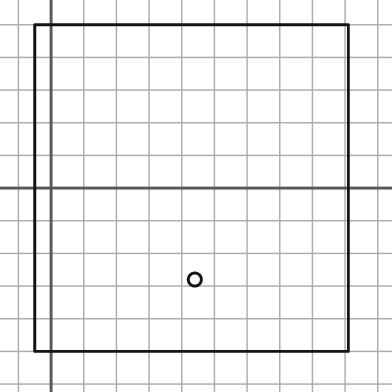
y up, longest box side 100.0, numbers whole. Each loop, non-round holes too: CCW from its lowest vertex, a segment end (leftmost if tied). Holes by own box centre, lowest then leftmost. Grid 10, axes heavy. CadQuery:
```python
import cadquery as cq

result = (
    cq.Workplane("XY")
    .moveTo(-5.0, -50.0)
    .lineTo(91.0, -50.0)
    .lineTo(91.0, 50.0)
    .lineTo(-5.0, 50.0)
    .close()
    .moveTo(44.0, -28.0)
    .circle(2.0)
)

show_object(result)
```